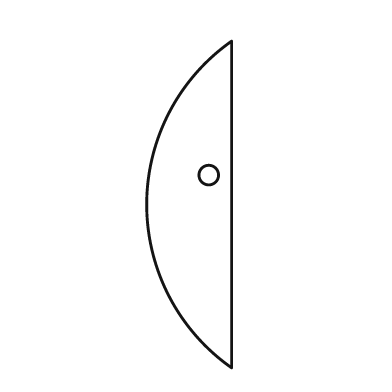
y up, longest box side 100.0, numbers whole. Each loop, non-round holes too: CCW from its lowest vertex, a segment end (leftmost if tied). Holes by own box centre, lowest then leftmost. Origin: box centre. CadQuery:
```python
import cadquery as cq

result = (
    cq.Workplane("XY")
    .moveTo(13.0, -50.0)
    .lineTo(13.0, 50.0)
    .threePointArc((-13.0, 0.0), (13.0, -50.0))
    .close()
    .moveTo(6.0, 9.0)
    .circle(3.0)
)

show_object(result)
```